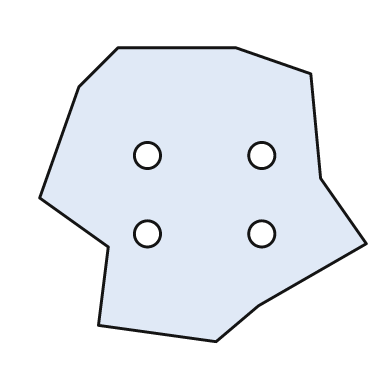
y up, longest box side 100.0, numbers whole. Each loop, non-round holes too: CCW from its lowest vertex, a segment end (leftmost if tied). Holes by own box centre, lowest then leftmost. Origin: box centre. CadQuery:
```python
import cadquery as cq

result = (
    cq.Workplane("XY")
    .moveTo(4.0, -45.0)
    .lineTo(17.0, -34.0)
    .lineTo(50.0, -15.0)
    .lineTo(36.0, 5.0)
    .lineTo(33.0, 37.0)
    .lineTo(10.0, 45.0)
    .lineTo(-26.0, 45.0)
    .lineTo(-38.0, 33.0)
    .lineTo(-50.0, -1.0)
    .lineTo(-29.0, -16.0)
    .lineTo(-32.0, -40.0)
    .close()
    .moveTo(-17.0, -12.0)
    .circle(4.0)
    .moveTo(18.0, -12.0)
    .circle(4.0)
    .moveTo(-17.0, 12.0)
    .circle(4.0)
    .moveTo(18.0, 12.0)
    .circle(4.0)
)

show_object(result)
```